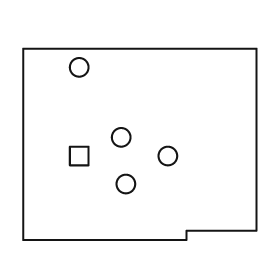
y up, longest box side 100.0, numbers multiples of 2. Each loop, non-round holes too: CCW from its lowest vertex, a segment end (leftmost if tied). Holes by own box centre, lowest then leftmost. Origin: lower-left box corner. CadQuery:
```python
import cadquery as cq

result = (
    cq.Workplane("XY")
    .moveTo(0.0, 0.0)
    .lineTo(70.0, 0.0)
    .lineTo(70.0, 4.0)
    .lineTo(100.0, 4.0)
    .lineTo(100.0, 82.0)
    .lineTo(0.0, 82.0)
    .close()
    .moveTo(44.0, 24.0)
    .circle(4.0)
    .moveTo(20.0, 32.0)
    .lineTo(28.0, 32.0)
    .lineTo(28.0, 40.0)
    .lineTo(20.0, 40.0)
    .close()
    .moveTo(62.0, 36.0)
    .circle(4.0)
    .moveTo(42.0, 44.0)
    .circle(4.0)
    .moveTo(24.0, 74.0)
    .circle(4.0)
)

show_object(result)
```